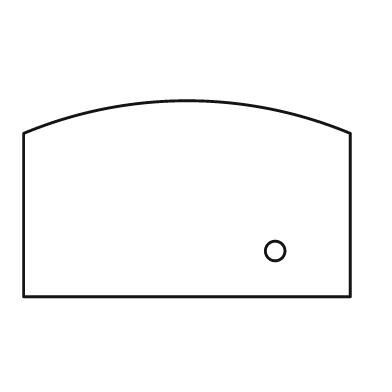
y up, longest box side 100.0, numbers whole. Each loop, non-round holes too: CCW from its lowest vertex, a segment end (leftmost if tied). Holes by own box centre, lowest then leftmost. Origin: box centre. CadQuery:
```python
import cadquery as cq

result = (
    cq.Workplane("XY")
    .moveTo(-50.0, -30.0)
    .lineTo(50.0, -30.0)
    .lineTo(50.0, 20.0)
    .threePointArc((0.0, 30.0), (-50.0, 20.0))
    .close()
    .moveTo(27.0, -16.0)
    .circle(3.0)
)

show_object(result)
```